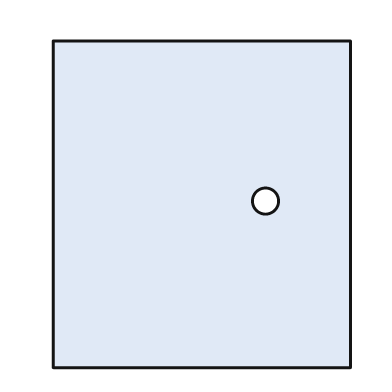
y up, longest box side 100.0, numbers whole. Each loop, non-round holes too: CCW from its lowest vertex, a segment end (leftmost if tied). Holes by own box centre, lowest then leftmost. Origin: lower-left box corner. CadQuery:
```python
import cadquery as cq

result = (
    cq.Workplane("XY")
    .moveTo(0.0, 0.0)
    .lineTo(91.0, 0.0)
    .lineTo(91.0, 100.0)
    .lineTo(0.0, 100.0)
    .close()
    .moveTo(65.0, 51.0)
    .circle(4.0)
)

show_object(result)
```